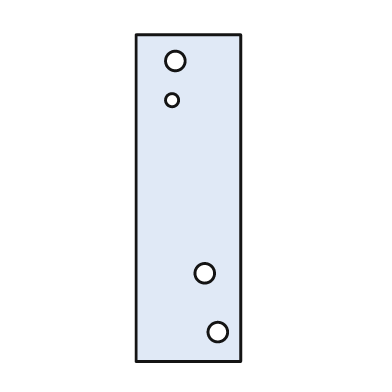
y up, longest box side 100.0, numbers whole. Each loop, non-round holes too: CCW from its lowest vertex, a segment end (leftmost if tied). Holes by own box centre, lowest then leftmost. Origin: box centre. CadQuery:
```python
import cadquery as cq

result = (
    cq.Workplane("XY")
    .moveTo(-16.0, -50.0)
    .lineTo(16.0, -50.0)
    .lineTo(16.0, 50.0)
    .lineTo(-16.0, 50.0)
    .close()
    .moveTo(9.0, -41.0)
    .circle(3.0)
    .moveTo(5.0, -23.0)
    .circle(3.0)
    .moveTo(-5.0, 30.0)
    .circle(2.0)
    .moveTo(-4.0, 42.0)
    .circle(3.0)
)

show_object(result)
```